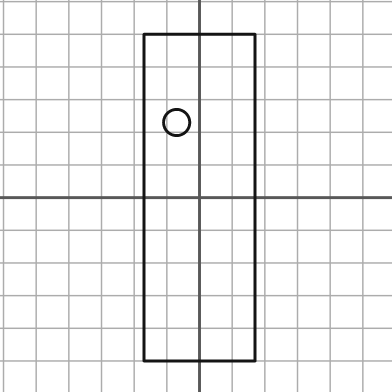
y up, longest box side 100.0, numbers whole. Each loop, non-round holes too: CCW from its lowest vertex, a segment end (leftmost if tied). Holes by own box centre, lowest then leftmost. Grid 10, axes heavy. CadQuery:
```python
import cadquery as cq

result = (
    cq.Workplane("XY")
    .moveTo(-17.0, -50.0)
    .lineTo(17.0, -50.0)
    .lineTo(17.0, 50.0)
    .lineTo(-17.0, 50.0)
    .close()
    .moveTo(-7.0, 23.0)
    .circle(4.0)
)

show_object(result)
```